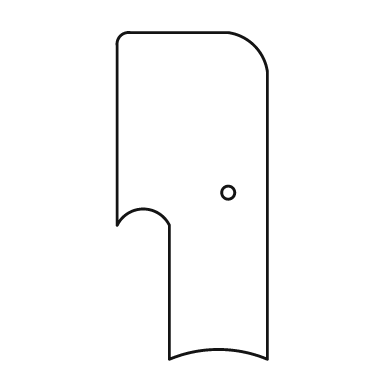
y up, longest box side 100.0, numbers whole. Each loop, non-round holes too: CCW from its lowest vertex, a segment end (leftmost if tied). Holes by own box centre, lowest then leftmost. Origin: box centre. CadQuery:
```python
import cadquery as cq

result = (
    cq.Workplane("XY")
    .moveTo(-7.0, -50.0)
    .threePointArc((8.0, -47.0), (23.0, -50.0))
    .lineTo(23.0, 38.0)
    .threePointArc((19.0, 46.0), (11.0, 50.0))
    .lineTo(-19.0, 50.0)
    .threePointArc((-22.0, 49.0), (-23.0, 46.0))
    .lineTo(-23.0, -9.0)
    .threePointArc((-15.0, -4.0), (-7.0, -9.0))
    .close()
    .moveTo(11.0, 1.0)
    .circle(2.0)
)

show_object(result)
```